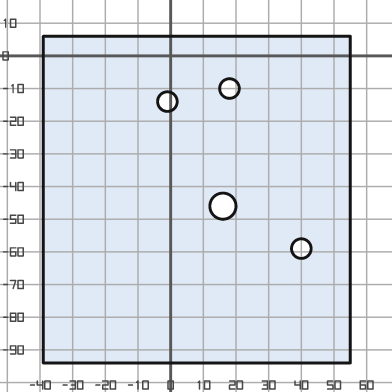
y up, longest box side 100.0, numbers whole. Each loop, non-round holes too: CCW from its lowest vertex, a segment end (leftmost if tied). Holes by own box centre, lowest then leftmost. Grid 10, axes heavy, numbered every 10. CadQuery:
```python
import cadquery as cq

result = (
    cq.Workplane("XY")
    .moveTo(-39.0, -94.0)
    .lineTo(55.0, -94.0)
    .lineTo(55.0, 6.0)
    .lineTo(-39.0, 6.0)
    .close()
    .moveTo(40.0, -59.0)
    .circle(3.0)
    .moveTo(16.0, -46.0)
    .circle(4.0)
    .moveTo(-1.0, -14.0)
    .circle(3.0)
    .moveTo(18.0, -10.0)
    .circle(3.0)
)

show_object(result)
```